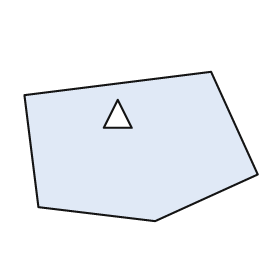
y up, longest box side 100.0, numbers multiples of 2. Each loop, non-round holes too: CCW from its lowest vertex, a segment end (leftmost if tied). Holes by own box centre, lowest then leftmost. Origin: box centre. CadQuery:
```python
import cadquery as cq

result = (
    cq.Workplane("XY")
    .moveTo(6.0, -32.0)
    .lineTo(50.0, -12.0)
    .lineTo(30.0, 32.0)
    .lineTo(-50.0, 22.0)
    .lineTo(-44.0, -26.0)
    .close()
    .moveTo(-16.0, 8.0)
    .lineTo(-4.0, 8.0)
    .lineTo(-10.0, 20.0)
    .close()
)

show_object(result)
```